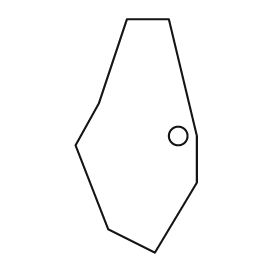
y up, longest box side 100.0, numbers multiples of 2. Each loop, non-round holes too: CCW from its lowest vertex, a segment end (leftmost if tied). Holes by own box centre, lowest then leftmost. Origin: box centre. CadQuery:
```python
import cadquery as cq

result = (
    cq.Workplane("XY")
    .moveTo(8.0, -50.0)
    .lineTo(26.0, -20.0)
    .lineTo(26.0, 0.0)
    .lineTo(14.0, 50.0)
    .lineTo(-4.0, 50.0)
    .lineTo(-16.0, 14.0)
    .lineTo(-26.0, -4.0)
    .lineTo(-12.0, -40.0)
    .close()
    .moveTo(18.0, 0.0)
    .circle(4.0)
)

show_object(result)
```